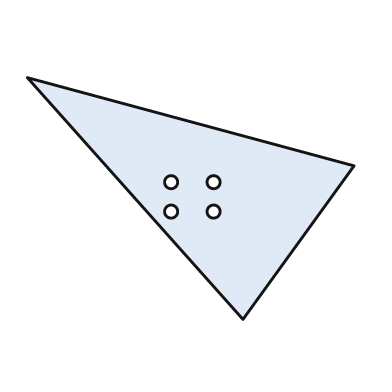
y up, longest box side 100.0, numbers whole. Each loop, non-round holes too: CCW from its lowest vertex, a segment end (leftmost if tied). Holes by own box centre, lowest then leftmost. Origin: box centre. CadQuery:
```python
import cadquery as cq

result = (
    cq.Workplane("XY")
    .moveTo(16.0, -37.0)
    .lineTo(50.0, 10.0)
    .lineTo(-50.0, 37.0)
    .close()
    .moveTo(-6.0, -4.0)
    .circle(2.0)
    .moveTo(7.0, -4.0)
    .circle(2.0)
    .moveTo(-6.0, 5.0)
    .circle(2.0)
    .moveTo(7.0, 5.0)
    .circle(2.0)
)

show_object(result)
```